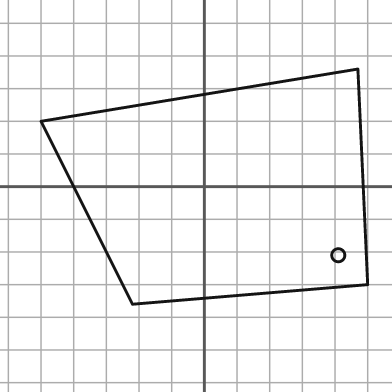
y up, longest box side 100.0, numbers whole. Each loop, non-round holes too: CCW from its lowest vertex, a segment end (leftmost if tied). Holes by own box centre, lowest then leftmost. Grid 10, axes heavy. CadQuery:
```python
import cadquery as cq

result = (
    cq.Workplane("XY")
    .moveTo(-22.0, -36.0)
    .lineTo(50.0, -30.0)
    .lineTo(47.0, 36.0)
    .lineTo(-50.0, 20.0)
    .close()
    .moveTo(41.0, -21.0)
    .circle(2.0)
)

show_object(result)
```